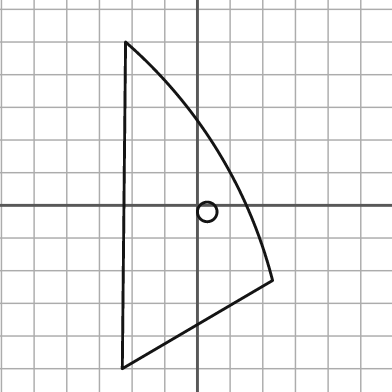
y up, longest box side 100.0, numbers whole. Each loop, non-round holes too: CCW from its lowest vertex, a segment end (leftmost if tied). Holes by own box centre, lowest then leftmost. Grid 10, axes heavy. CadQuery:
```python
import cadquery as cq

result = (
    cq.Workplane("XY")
    .moveTo(-23.0, -50.0)
    .lineTo(23.0, -23.0)
    .threePointArc((6.0, 17.0), (-22.0, 50.0))
    .close()
    .moveTo(3.0, -2.0)
    .circle(3.0)
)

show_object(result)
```